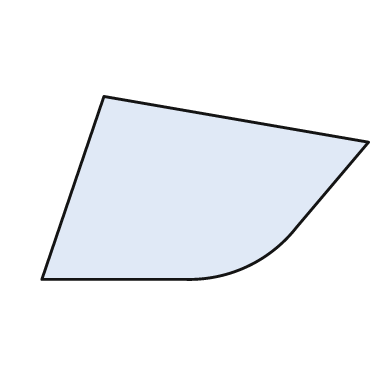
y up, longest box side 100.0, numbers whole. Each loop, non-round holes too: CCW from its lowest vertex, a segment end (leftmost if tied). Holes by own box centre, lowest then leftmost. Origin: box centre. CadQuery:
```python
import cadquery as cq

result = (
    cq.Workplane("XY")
    .moveTo(-50.0, -28.0)
    .lineTo(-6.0, -28.0)
    .threePointArc((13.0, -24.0), (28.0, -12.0))
    .lineTo(50.0, 14.0)
    .lineTo(-31.0, 28.0)
    .close()
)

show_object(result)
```